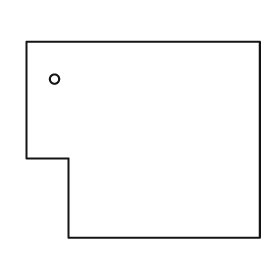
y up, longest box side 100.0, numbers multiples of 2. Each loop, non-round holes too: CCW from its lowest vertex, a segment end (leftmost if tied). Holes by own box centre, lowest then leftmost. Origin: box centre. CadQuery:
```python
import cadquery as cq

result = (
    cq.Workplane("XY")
    .moveTo(-32.0, -42.0)
    .lineTo(50.0, -42.0)
    .lineTo(50.0, 42.0)
    .lineTo(-50.0, 42.0)
    .lineTo(-50.0, -8.0)
    .lineTo(-32.0, -8.0)
    .close()
    .moveTo(-38.0, 26.0)
    .circle(2.0)
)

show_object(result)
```